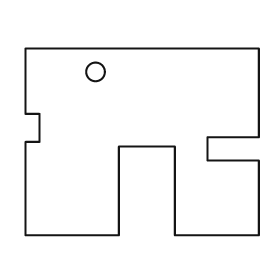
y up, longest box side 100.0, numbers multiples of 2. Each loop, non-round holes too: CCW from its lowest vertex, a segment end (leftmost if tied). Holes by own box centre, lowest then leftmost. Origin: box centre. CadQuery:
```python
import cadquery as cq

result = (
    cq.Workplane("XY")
    .moveTo(-50.0, -40.0)
    .lineTo(-10.0, -40.0)
    .lineTo(-10.0, -2.0)
    .lineTo(14.0, -2.0)
    .lineTo(14.0, -40.0)
    .lineTo(50.0, -40.0)
    .lineTo(50.0, -8.0)
    .lineTo(28.0, -8.0)
    .lineTo(28.0, 2.0)
    .lineTo(50.0, 2.0)
    .lineTo(50.0, 40.0)
    .lineTo(-50.0, 40.0)
    .lineTo(-50.0, 12.0)
    .lineTo(-44.0, 12.0)
    .lineTo(-44.0, 0.0)
    .lineTo(-50.0, 0.0)
    .close()
    .moveTo(-20.0, 30.0)
    .circle(4.0)
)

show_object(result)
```